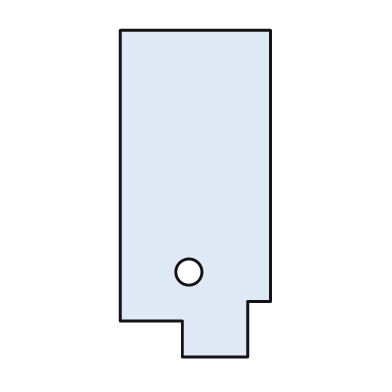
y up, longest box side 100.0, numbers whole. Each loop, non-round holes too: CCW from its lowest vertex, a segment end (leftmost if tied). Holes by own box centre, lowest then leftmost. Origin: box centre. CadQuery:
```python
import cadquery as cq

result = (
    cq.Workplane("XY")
    .moveTo(-4.0, -50.0)
    .lineTo(16.0, -50.0)
    .lineTo(16.0, -33.0)
    .lineTo(23.0, -33.0)
    .lineTo(23.0, 50.0)
    .lineTo(-23.0, 50.0)
    .lineTo(-23.0, -39.0)
    .lineTo(-4.0, -39.0)
    .close()
    .moveTo(-2.0, -24.0)
    .circle(4.0)
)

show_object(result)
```